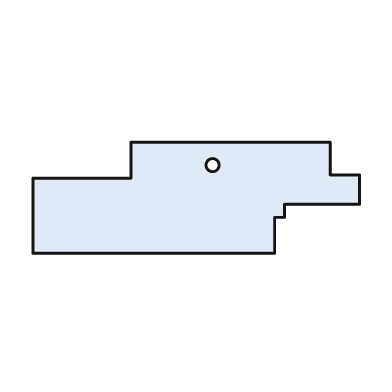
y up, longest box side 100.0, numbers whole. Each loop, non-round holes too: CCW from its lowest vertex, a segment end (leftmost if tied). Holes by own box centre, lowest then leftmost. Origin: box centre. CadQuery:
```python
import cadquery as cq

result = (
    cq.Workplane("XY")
    .moveTo(-50.0, -17.0)
    .lineTo(24.0, -17.0)
    .lineTo(24.0, -6.0)
    .lineTo(27.0, -6.0)
    .lineTo(27.0, -2.0)
    .lineTo(50.0, -2.0)
    .lineTo(50.0, 7.0)
    .lineTo(41.0, 7.0)
    .lineTo(41.0, 17.0)
    .lineTo(-20.0, 17.0)
    .lineTo(-20.0, 6.0)
    .lineTo(-50.0, 6.0)
    .close()
    .moveTo(5.0, 10.0)
    .circle(2.0)
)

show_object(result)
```